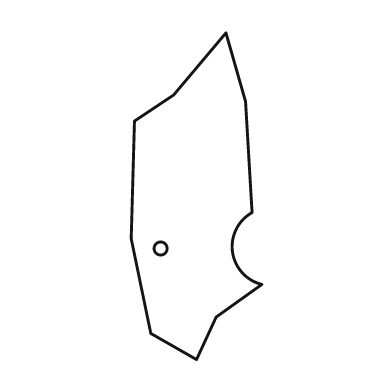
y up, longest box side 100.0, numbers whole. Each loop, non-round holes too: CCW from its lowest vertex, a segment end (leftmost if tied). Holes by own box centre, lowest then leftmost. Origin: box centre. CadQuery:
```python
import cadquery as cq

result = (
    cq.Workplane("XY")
    .moveTo(0.0, -50.0)
    .lineTo(6.0, -37.0)
    .lineTo(20.0, -27.0)
    .threePointArc((11.0, -17.0), (17.0, -5.0))
    .lineTo(15.0, 29.0)
    .lineTo(9.0, 50.0)
    .lineTo(-7.0, 31.0)
    .lineTo(-19.0, 23.0)
    .lineTo(-20.0, -13.0)
    .lineTo(-14.0, -42.0)
    .close()
    .moveTo(-11.0, -16.0)
    .circle(2.0)
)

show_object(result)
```